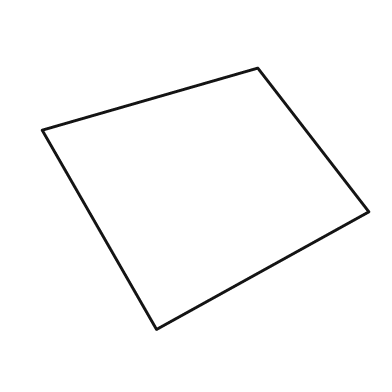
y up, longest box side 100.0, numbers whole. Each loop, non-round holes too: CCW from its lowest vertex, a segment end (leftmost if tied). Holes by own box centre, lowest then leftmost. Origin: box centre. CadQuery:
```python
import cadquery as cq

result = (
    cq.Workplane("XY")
    .moveTo(-15.0, -40.0)
    .lineTo(50.0, -4.0)
    .lineTo(16.0, 40.0)
    .lineTo(-50.0, 21.0)
    .close()
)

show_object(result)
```